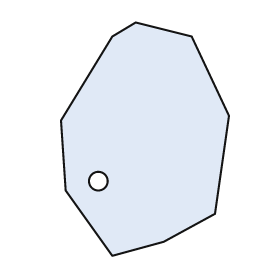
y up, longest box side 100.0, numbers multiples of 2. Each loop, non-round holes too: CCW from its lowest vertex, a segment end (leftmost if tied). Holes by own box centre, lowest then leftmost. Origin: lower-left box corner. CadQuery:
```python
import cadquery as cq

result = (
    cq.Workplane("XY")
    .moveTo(22.0, 0.0)
    .lineTo(44.0, 6.0)
    .lineTo(66.0, 18.0)
    .lineTo(72.0, 60.0)
    .lineTo(56.0, 94.0)
    .lineTo(32.0, 100.0)
    .lineTo(22.0, 94.0)
    .lineTo(0.0, 58.0)
    .lineTo(2.0, 28.0)
    .close()
    .moveTo(16.0, 32.0)
    .circle(4.0)
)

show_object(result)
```